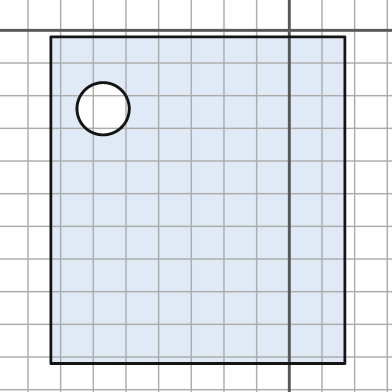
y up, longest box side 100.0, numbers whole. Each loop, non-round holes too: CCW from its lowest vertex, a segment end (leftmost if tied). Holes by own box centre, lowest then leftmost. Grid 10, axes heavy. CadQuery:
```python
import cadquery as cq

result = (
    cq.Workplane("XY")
    .moveTo(-73.0, -102.0)
    .lineTo(17.0, -102.0)
    .lineTo(17.0, -2.0)
    .lineTo(-73.0, -2.0)
    .close()
    .moveTo(-57.0, -24.0)
    .circle(8.0)
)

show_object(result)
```